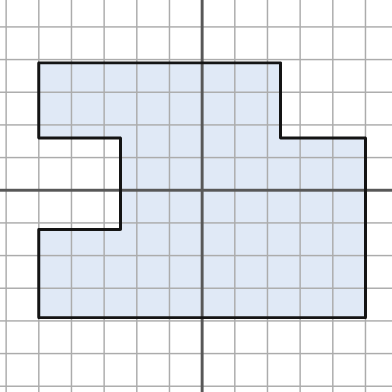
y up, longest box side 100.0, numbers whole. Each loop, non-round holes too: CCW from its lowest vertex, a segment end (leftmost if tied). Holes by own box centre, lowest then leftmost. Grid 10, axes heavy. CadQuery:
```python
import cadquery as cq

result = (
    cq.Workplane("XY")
    .moveTo(-50.0, -39.0)
    .lineTo(50.0, -39.0)
    .lineTo(50.0, 16.0)
    .lineTo(24.0, 16.0)
    .lineTo(24.0, 39.0)
    .lineTo(-50.0, 39.0)
    .lineTo(-50.0, 16.0)
    .lineTo(-25.0, 16.0)
    .lineTo(-25.0, -12.0)
    .lineTo(-50.0, -12.0)
    .close()
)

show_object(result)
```